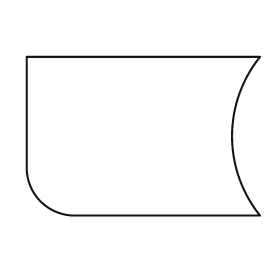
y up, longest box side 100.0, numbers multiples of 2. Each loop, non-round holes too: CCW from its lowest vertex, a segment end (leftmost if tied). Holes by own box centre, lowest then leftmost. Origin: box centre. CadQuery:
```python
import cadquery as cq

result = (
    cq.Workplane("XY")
    .moveTo(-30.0, -34.0)
    .lineTo(50.0, -34.0)
    .threePointArc((38.0, 0.0), (50.0, 34.0))
    .lineTo(-50.0, 34.0)
    .lineTo(-50.0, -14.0)
    .threePointArc((-44.0, -28.0), (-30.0, -34.0))
    .close()
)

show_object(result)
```